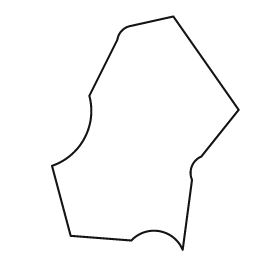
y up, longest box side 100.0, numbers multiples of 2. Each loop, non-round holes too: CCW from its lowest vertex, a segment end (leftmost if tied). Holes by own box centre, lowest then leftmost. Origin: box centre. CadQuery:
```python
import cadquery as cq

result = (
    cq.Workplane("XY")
    .moveTo(16.0, -50.0)
    .lineTo(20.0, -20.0)
    .threePointArc((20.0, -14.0), (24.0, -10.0))
    .lineTo(40.0, 10.0)
    .lineTo(12.0, 50.0)
    .lineTo(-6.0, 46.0)
    .threePointArc((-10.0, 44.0), (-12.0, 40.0))
    .lineTo(-24.0, 16.0)
    .threePointArc((-26.0, -2.0), (-40.0, -14.0))
    .lineTo(-32.0, -44.0)
    .lineTo(-6.0, -46.0)
    .threePointArc((6.0, -42.0), (16.0, -50.0))
    .close()
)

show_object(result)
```